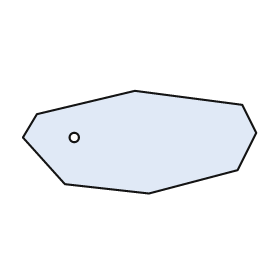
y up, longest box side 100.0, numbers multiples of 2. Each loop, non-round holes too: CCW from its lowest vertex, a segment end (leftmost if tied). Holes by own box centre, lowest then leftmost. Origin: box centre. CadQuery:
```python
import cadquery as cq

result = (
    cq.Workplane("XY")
    .moveTo(4.0, -22.0)
    .lineTo(42.0, -12.0)
    .lineTo(50.0, 4.0)
    .lineTo(44.0, 16.0)
    .lineTo(-2.0, 22.0)
    .lineTo(-44.0, 12.0)
    .lineTo(-50.0, 2.0)
    .lineTo(-32.0, -18.0)
    .close()
    .moveTo(-28.0, 2.0)
    .circle(2.0)
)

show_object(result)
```